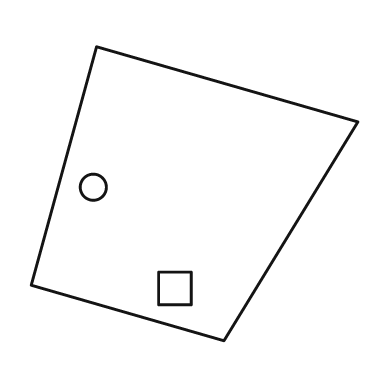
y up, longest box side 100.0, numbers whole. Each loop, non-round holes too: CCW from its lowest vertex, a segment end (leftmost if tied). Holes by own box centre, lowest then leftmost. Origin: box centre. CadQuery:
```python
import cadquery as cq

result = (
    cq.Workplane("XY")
    .moveTo(9.0, -45.0)
    .lineTo(50.0, 22.0)
    .lineTo(-30.0, 45.0)
    .lineTo(-50.0, -28.0)
    .close()
    .moveTo(-11.0, -34.0)
    .lineTo(-1.0, -34.0)
    .lineTo(-1.0, -24.0)
    .lineTo(-11.0, -24.0)
    .close()
    .moveTo(-31.0, 2.0)
    .circle(4.0)
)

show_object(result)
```